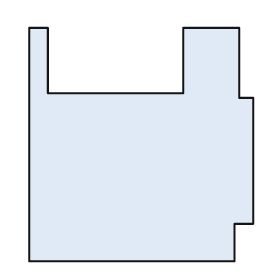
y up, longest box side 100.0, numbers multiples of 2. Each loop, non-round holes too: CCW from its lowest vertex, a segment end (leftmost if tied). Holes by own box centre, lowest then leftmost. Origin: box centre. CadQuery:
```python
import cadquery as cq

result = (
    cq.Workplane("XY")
    .moveTo(-48.0, -50.0)
    .lineTo(40.0, -50.0)
    .lineTo(40.0, -34.0)
    .lineTo(48.0, -34.0)
    .lineTo(48.0, 20.0)
    .lineTo(42.0, 20.0)
    .lineTo(42.0, 50.0)
    .lineTo(18.0, 50.0)
    .lineTo(18.0, 22.0)
    .lineTo(-40.0, 22.0)
    .lineTo(-40.0, 50.0)
    .lineTo(-48.0, 50.0)
    .close()
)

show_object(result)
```